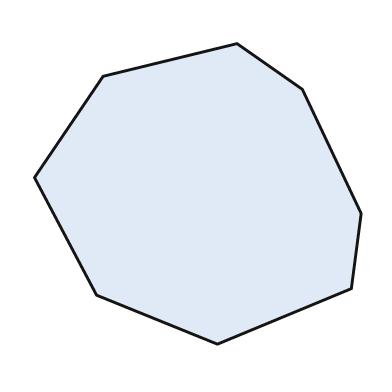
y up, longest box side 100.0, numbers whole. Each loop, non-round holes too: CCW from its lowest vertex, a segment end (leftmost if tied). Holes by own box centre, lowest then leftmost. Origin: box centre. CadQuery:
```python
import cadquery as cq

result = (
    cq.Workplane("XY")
    .moveTo(6.0, -46.0)
    .lineTo(47.0, -29.0)
    .lineTo(50.0, -6.0)
    .lineTo(32.0, 32.0)
    .lineTo(12.0, 46.0)
    .lineTo(-29.0, 36.0)
    .lineTo(-50.0, 5.0)
    .lineTo(-31.0, -31.0)
    .close()
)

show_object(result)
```